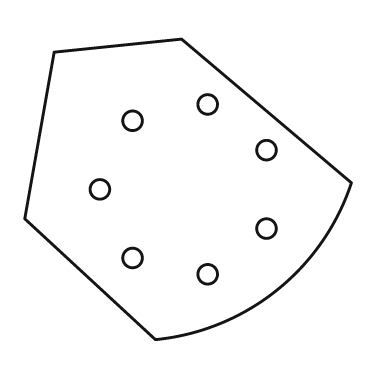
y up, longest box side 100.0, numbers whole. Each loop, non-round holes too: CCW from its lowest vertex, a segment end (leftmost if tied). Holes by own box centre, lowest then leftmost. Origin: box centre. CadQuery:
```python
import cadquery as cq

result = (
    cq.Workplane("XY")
    .moveTo(-10.0, -46.0)
    .threePointArc((27.0, -31.0), (50.0, 2.0))
    .lineTo(-2.0, 46.0)
    .lineTo(-41.0, 42.0)
    .lineTo(-50.0, -9.0)
    .close()
    .moveTo(6.0, -26.0)
    .circle(3.0)
    .moveTo(-17.0, -21.0)
    .circle(3.0)
    .moveTo(24.0, -12.0)
    .circle(3.0)
    .moveTo(-27.0, 0.0)
    .circle(3.0)
    .moveTo(24.0, 12.0)
    .circle(3.0)
    .moveTo(-17.0, 21.0)
    .circle(3.0)
    .moveTo(6.0, 26.0)
    .circle(3.0)
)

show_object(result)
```